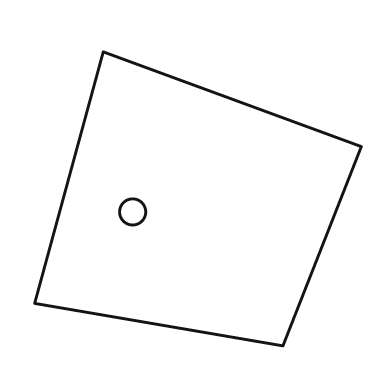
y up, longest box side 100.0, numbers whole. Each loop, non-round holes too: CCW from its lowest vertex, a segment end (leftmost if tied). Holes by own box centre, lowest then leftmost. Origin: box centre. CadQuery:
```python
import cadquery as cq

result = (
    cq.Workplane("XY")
    .moveTo(26.0, -45.0)
    .lineTo(50.0, 16.0)
    .lineTo(-29.0, 45.0)
    .lineTo(-50.0, -32.0)
    .close()
    .moveTo(-20.0, -4.0)
    .circle(4.0)
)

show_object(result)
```